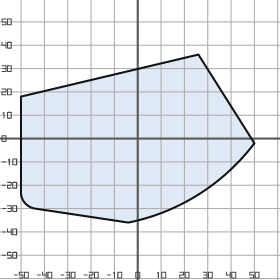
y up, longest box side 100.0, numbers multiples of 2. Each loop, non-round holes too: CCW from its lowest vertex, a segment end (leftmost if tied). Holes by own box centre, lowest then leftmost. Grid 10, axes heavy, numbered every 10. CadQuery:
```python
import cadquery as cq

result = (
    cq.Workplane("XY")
    .moveTo(-4.0, -36.0)
    .threePointArc((26.0, -24.0), (50.0, -2.0))
    .lineTo(26.0, 36.0)
    .lineTo(-50.0, 18.0)
    .lineTo(-50.0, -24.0)
    .threePointArc((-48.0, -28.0), (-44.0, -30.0))
    .close()
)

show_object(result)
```